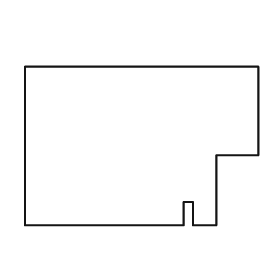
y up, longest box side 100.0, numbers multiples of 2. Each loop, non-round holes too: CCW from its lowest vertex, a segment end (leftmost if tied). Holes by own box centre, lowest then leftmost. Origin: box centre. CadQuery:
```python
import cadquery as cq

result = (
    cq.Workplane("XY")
    .moveTo(-50.0, -34.0)
    .lineTo(18.0, -34.0)
    .lineTo(18.0, -24.0)
    .lineTo(22.0, -24.0)
    .lineTo(22.0, -34.0)
    .lineTo(32.0, -34.0)
    .lineTo(32.0, -4.0)
    .lineTo(50.0, -4.0)
    .lineTo(50.0, 34.0)
    .lineTo(-50.0, 34.0)
    .close()
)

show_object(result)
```